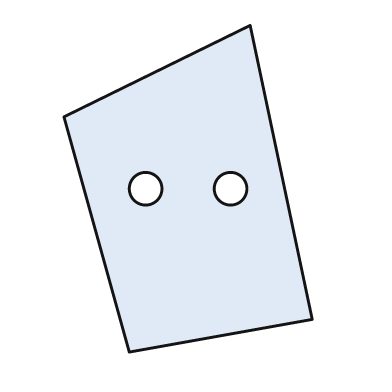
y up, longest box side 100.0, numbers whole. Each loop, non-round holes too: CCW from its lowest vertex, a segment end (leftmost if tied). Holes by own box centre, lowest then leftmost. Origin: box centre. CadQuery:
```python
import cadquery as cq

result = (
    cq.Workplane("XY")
    .moveTo(-18.0, -50.0)
    .lineTo(38.0, -40.0)
    .lineTo(19.0, 50.0)
    .lineTo(-38.0, 22.0)
    .close()
    .moveTo(-13.0, 0.0)
    .circle(5.0)
    .moveTo(13.0, 0.0)
    .circle(5.0)
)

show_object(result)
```